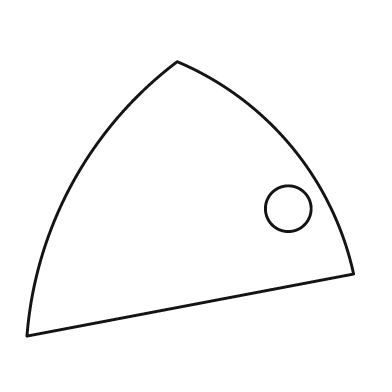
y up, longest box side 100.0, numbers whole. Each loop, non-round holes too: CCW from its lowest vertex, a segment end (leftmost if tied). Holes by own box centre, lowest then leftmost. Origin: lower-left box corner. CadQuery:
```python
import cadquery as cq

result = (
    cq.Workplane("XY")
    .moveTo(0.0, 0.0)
    .lineTo(100.0, 19.0)
    .threePointArc((81.0, 58.0), (46.0, 84.0))
    .threePointArc((14.0, 47.0), (0.0, 0.0))
    .close()
    .moveTo(80.0, 39.0)
    .circle(7.0)
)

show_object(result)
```